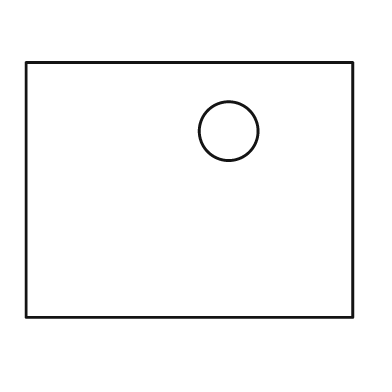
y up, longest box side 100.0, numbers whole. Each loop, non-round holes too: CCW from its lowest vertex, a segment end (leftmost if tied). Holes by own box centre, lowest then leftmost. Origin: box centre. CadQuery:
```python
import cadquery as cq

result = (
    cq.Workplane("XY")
    .moveTo(-50.0, -39.0)
    .lineTo(50.0, -39.0)
    .lineTo(50.0, 39.0)
    .lineTo(-50.0, 39.0)
    .close()
    .moveTo(12.0, 18.0)
    .circle(9.0)
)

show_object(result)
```